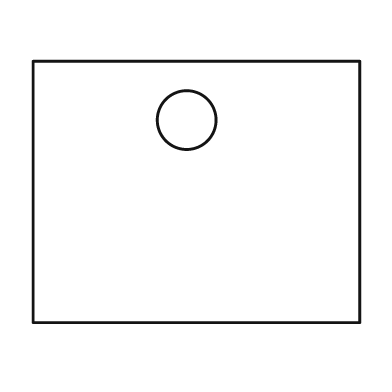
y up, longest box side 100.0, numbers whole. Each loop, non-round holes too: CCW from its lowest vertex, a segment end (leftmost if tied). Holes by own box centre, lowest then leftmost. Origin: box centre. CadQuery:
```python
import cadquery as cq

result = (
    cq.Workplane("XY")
    .moveTo(-50.0, -40.0)
    .lineTo(50.0, -40.0)
    .lineTo(50.0, 40.0)
    .lineTo(-50.0, 40.0)
    .close()
    .moveTo(-3.0, 22.0)
    .circle(9.0)
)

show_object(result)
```